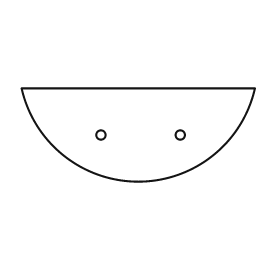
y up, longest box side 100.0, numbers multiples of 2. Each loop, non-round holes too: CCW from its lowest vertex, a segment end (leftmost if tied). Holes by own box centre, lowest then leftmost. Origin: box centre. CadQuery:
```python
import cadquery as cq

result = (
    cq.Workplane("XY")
    .moveTo(-50.0, 20.0)
    .threePointArc((0.0, -20.0), (50.0, 20.0))
    .close()
    .moveTo(-16.0, 0.0)
    .circle(2.0)
    .moveTo(18.0, 0.0)
    .circle(2.0)
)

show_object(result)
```